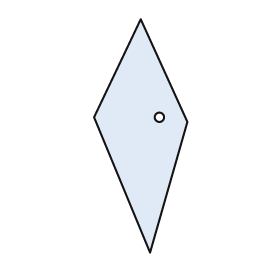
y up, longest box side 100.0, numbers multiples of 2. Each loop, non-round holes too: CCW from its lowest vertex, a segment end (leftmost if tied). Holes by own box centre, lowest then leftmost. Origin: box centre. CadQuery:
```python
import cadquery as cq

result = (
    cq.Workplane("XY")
    .moveTo(4.0, -50.0)
    .lineTo(20.0, 6.0)
    .lineTo(0.0, 50.0)
    .lineTo(-20.0, 8.0)
    .close()
    .moveTo(8.0, 8.0)
    .circle(2.0)
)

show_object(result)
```